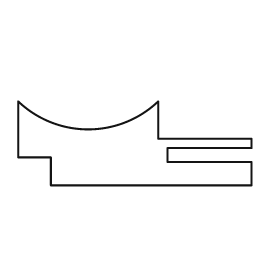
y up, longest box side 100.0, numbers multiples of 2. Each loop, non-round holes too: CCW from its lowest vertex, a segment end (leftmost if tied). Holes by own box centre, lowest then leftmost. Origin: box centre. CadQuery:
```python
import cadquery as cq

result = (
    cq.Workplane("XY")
    .moveTo(-36.0, -18.0)
    .lineTo(50.0, -18.0)
    .lineTo(50.0, -8.0)
    .lineTo(14.0, -8.0)
    .lineTo(14.0, -2.0)
    .lineTo(50.0, -2.0)
    .lineTo(50.0, 2.0)
    .lineTo(10.0, 2.0)
    .lineTo(10.0, 18.0)
    .threePointArc((-20.0, 6.0), (-50.0, 18.0))
    .lineTo(-50.0, -6.0)
    .lineTo(-36.0, -6.0)
    .close()
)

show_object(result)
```